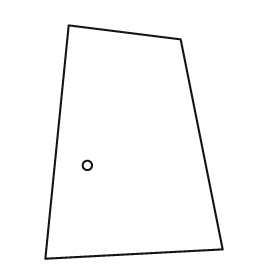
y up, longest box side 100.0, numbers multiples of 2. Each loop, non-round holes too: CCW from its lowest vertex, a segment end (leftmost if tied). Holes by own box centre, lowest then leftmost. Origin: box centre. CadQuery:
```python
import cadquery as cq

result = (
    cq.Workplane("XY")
    .moveTo(-38.0, -50.0)
    .lineTo(38.0, -46.0)
    .lineTo(20.0, 44.0)
    .lineTo(-28.0, 50.0)
    .close()
    .moveTo(-20.0, -10.0)
    .circle(2.0)
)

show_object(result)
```